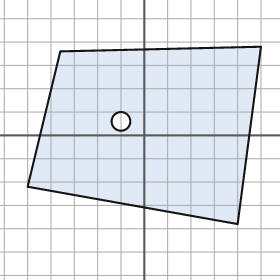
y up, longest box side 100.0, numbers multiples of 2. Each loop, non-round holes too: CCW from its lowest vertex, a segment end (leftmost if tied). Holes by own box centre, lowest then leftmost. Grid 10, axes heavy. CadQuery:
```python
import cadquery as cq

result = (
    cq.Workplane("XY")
    .moveTo(40.0, -38.0)
    .lineTo(50.0, 38.0)
    .lineTo(-36.0, 36.0)
    .lineTo(-50.0, -22.0)
    .close()
    .moveTo(-10.0, 6.0)
    .circle(4.0)
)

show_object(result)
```